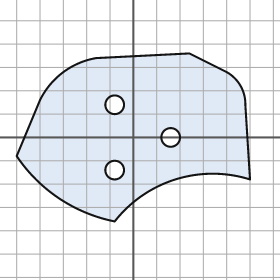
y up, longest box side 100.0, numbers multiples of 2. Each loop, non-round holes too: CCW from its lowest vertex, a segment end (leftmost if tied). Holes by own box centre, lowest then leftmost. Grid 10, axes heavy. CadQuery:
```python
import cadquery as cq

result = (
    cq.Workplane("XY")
    .moveTo(-8.0, -36.0)
    .threePointArc((18.0, -18.0), (50.0, -18.0))
    .lineTo(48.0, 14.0)
    .threePointArc((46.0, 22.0), (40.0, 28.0))
    .lineTo(24.0, 36.0)
    .lineTo(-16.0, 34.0)
    .threePointArc((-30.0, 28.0), (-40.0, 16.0))
    .lineTo(-50.0, -8.0)
    .threePointArc((-32.0, -26.0), (-8.0, -36.0))
    .close()
    .moveTo(-8.0, -14.0)
    .circle(4.0)
    .moveTo(16.0, 0.0)
    .circle(4.0)
    .moveTo(-8.0, 14.0)
    .circle(4.0)
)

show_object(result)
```